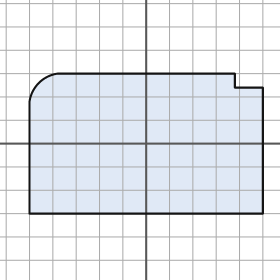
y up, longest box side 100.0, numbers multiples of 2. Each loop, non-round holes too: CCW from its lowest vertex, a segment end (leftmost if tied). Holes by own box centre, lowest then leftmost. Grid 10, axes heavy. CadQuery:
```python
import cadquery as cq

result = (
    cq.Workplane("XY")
    .moveTo(-50.0, -30.0)
    .lineTo(50.0, -30.0)
    .lineTo(50.0, 24.0)
    .lineTo(38.0, 24.0)
    .lineTo(38.0, 30.0)
    .lineTo(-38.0, 30.0)
    .threePointArc((-46.0, 26.0), (-50.0, 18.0))
    .close()
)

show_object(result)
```